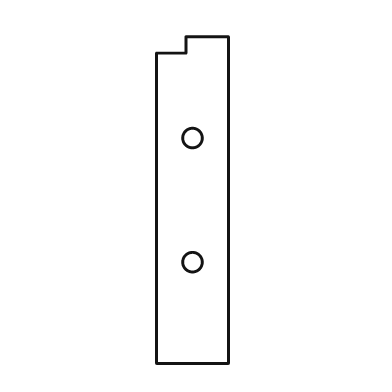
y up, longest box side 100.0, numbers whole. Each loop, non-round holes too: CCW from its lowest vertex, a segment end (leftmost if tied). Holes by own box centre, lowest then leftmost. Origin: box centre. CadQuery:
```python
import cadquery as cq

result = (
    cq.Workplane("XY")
    .moveTo(-11.0, -50.0)
    .lineTo(11.0, -50.0)
    .lineTo(11.0, 50.0)
    .lineTo(-2.0, 50.0)
    .lineTo(-2.0, 45.0)
    .lineTo(-11.0, 45.0)
    .close()
    .moveTo(0.0, -19.0)
    .circle(3.0)
    .moveTo(0.0, 19.0)
    .circle(3.0)
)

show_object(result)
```